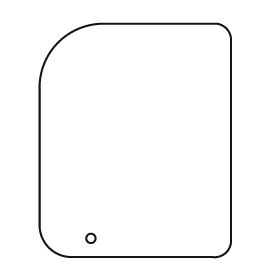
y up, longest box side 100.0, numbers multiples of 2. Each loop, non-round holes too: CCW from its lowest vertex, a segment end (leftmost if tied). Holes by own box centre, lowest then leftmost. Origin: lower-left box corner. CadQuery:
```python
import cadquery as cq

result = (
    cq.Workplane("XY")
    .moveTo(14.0, 0.0)
    .lineTo(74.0, 0.0)
    .threePointArc((80.0, 2.0), (82.0, 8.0))
    .lineTo(82.0, 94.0)
    .threePointArc((80.0, 98.0), (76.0, 100.0))
    .lineTo(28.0, 100.0)
    .threePointArc((8.0, 92.0), (0.0, 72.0))
    .lineTo(0.0, 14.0)
    .threePointArc((4.0, 4.0), (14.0, 0.0))
    .close()
    .moveTo(22.0, 8.0)
    .circle(2.0)
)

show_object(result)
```